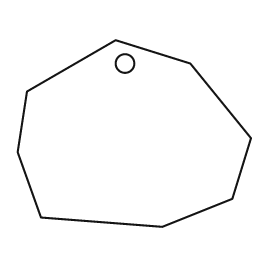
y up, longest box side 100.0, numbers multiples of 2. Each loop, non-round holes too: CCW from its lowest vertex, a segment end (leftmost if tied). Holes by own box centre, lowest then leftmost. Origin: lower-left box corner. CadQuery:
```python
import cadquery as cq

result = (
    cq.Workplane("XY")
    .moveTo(62.0, 0.0)
    .lineTo(92.0, 12.0)
    .lineTo(100.0, 38.0)
    .lineTo(74.0, 70.0)
    .lineTo(42.0, 80.0)
    .lineTo(4.0, 58.0)
    .lineTo(0.0, 32.0)
    .lineTo(10.0, 4.0)
    .close()
    .moveTo(46.0, 70.0)
    .circle(4.0)
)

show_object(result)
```